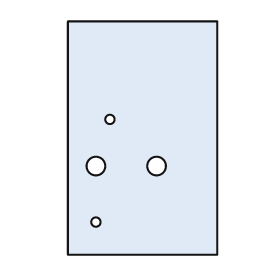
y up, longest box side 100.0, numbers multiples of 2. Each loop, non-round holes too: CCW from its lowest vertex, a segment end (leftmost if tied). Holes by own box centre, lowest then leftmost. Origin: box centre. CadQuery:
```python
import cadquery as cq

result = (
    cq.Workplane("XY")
    .moveTo(-32.0, -50.0)
    .lineTo(32.0, -50.0)
    .lineTo(32.0, 50.0)
    .lineTo(-32.0, 50.0)
    .close()
    .moveTo(-20.0, -36.0)
    .circle(2.0)
    .moveTo(-20.0, -12.0)
    .circle(4.0)
    .moveTo(6.0, -12.0)
    .circle(4.0)
    .moveTo(-14.0, 8.0)
    .circle(2.0)
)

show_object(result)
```